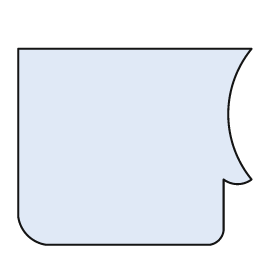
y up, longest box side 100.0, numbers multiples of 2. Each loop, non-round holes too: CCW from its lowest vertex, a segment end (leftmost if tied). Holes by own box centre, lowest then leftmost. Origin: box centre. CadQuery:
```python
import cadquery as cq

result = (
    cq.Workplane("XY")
    .moveTo(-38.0, -42.0)
    .lineTo(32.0, -42.0)
    .threePointArc((36.0, -40.0), (38.0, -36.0))
    .lineTo(38.0, -14.0)
    .threePointArc((44.0, -16.0), (50.0, -14.0))
    .threePointArc((40.0, 14.0), (50.0, 42.0))
    .lineTo(-50.0, 42.0)
    .lineTo(-50.0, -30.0)
    .threePointArc((-46.0, -38.0), (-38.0, -42.0))
    .close()
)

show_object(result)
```